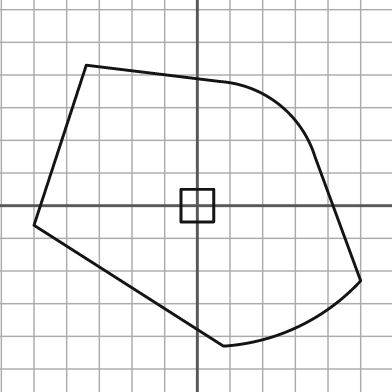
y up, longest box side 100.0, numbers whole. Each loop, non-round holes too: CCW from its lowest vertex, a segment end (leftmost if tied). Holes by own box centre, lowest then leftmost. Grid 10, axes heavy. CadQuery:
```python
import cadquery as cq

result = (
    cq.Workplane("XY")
    .moveTo(8.0, -43.0)
    .threePointArc((31.0, -37.0), (50.0, -23.0))
    .lineTo(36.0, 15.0)
    .threePointArc((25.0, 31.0), (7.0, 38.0))
    .lineTo(-34.0, 43.0)
    .lineTo(-50.0, -6.0)
    .close()
    .moveTo(-5.0, -5.0)
    .lineTo(5.0, -5.0)
    .lineTo(5.0, 5.0)
    .lineTo(-5.0, 5.0)
    .close()
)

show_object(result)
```